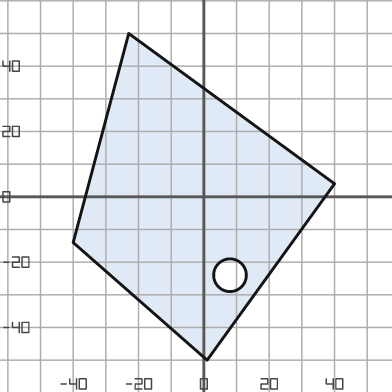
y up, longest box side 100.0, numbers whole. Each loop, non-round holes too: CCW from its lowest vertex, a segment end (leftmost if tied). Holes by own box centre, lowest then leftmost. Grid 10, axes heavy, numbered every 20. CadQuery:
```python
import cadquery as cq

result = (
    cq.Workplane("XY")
    .moveTo(1.0, -50.0)
    .lineTo(40.0, 4.0)
    .lineTo(-23.0, 50.0)
    .lineTo(-40.0, -14.0)
    .close()
    .moveTo(8.0, -24.0)
    .circle(5.0)
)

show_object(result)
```